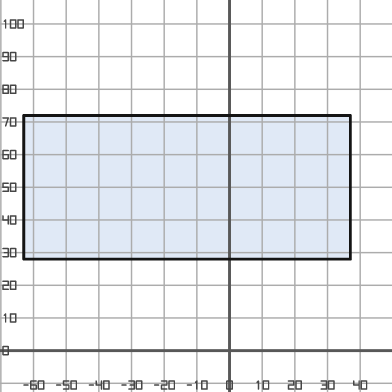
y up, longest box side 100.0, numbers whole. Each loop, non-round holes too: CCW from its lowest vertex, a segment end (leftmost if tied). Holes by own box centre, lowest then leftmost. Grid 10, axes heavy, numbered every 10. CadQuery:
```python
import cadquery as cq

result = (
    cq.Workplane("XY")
    .moveTo(-63.0, 28.0)
    .lineTo(37.0, 28.0)
    .lineTo(37.0, 72.0)
    .lineTo(-63.0, 72.0)
    .close()
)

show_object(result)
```